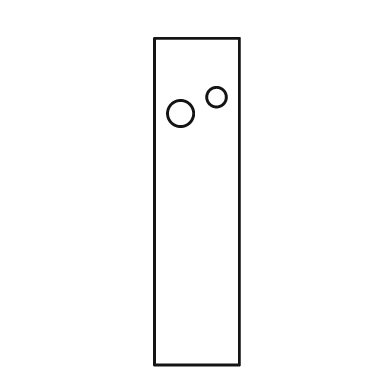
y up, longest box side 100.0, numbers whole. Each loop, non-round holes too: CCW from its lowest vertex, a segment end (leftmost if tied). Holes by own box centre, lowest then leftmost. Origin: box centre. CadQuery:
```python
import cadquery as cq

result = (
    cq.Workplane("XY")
    .moveTo(-13.0, -50.0)
    .lineTo(13.0, -50.0)
    .lineTo(13.0, 50.0)
    .lineTo(-13.0, 50.0)
    .close()
    .moveTo(-5.0, 27.0)
    .circle(4.0)
    .moveTo(6.0, 32.0)
    .circle(3.0)
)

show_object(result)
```